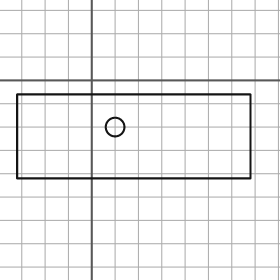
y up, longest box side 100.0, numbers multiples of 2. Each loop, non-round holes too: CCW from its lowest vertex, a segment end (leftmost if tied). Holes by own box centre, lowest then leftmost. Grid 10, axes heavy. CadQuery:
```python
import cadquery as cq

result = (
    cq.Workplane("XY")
    .moveTo(-32.0, -42.0)
    .lineTo(68.0, -42.0)
    .lineTo(68.0, -6.0)
    .lineTo(-32.0, -6.0)
    .close()
    .moveTo(10.0, -20.0)
    .circle(4.0)
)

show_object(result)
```